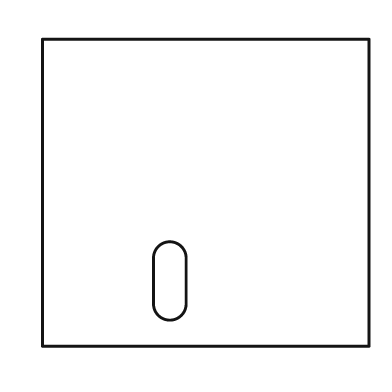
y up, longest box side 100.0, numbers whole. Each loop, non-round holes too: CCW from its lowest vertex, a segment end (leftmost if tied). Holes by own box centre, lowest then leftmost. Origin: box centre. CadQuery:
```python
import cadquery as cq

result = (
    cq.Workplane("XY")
    .moveTo(-50.0, -47.0)
    .lineTo(50.0, -47.0)
    .lineTo(50.0, 47.0)
    .lineTo(-50.0, 47.0)
    .close()
    .moveTo(-16.0, -34.0)
    .threePointArc((-11.0, -39.0), (-6.0, -34.0))
    .lineTo(-6.0, -20.0)
    .threePointArc((-11.0, -15.0), (-16.0, -20.0))
    .close()
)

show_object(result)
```